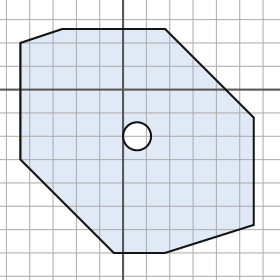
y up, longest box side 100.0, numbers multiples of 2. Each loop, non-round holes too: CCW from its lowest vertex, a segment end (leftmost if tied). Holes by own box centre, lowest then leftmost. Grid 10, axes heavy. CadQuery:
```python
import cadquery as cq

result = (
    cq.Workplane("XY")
    .moveTo(-4.0, -70.0)
    .lineTo(18.0, -70.0)
    .lineTo(56.0, -58.0)
    .lineTo(56.0, -12.0)
    .lineTo(18.0, 26.0)
    .lineTo(-26.0, 26.0)
    .lineTo(-44.0, 20.0)
    .lineTo(-44.0, -30.0)
    .close()
    .moveTo(6.0, -20.0)
    .circle(6.0)
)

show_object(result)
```